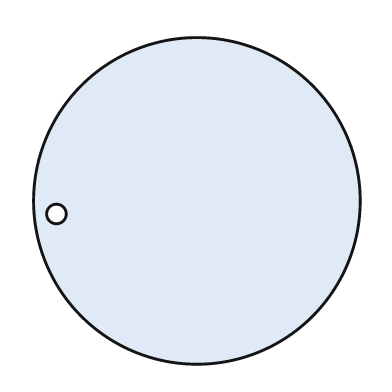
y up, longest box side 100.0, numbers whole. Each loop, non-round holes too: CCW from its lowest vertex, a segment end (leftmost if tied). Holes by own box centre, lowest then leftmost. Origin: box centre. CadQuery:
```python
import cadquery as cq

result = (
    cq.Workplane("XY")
    .moveTo(0.0, 0.0)
    .circle(50.0)
    .moveTo(-43.0, -4.0)
    .circle(3.0)
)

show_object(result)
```